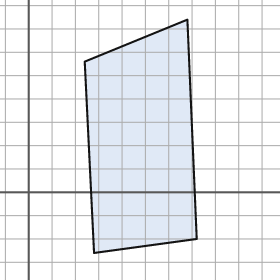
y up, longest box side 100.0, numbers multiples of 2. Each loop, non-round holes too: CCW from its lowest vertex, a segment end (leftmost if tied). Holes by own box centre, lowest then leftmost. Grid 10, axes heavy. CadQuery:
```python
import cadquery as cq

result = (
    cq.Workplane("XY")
    .moveTo(28.0, -26.0)
    .lineTo(72.0, -20.0)
    .lineTo(68.0, 74.0)
    .lineTo(24.0, 56.0)
    .close()
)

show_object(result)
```